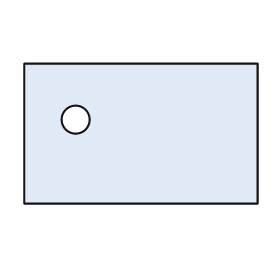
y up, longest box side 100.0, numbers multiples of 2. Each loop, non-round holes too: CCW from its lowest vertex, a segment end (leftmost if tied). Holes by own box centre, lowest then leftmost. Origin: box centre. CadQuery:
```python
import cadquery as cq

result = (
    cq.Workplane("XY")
    .moveTo(-50.0, -30.0)
    .lineTo(50.0, -30.0)
    .lineTo(50.0, 30.0)
    .lineTo(-50.0, 30.0)
    .close()
    .moveTo(-28.0, 6.0)
    .circle(6.0)
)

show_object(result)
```